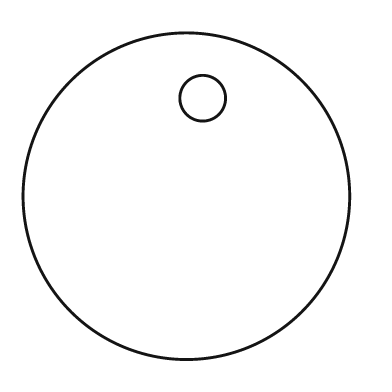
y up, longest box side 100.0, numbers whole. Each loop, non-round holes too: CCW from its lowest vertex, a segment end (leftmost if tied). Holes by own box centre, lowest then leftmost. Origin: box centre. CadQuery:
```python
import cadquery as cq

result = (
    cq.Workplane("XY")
    .moveTo(0.0, 0.0)
    .circle(50.0)
    .moveTo(5.0, 30.0)
    .circle(7.0)
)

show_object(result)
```